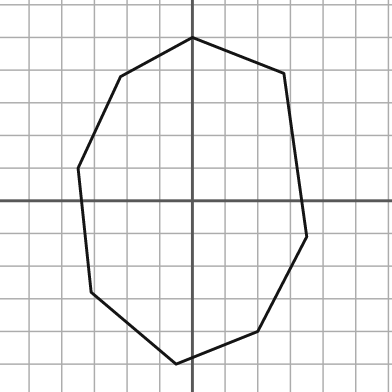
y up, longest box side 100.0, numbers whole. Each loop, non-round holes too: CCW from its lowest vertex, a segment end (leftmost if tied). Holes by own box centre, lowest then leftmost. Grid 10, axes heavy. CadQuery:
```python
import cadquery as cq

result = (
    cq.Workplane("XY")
    .moveTo(-5.0, -50.0)
    .lineTo(20.0, -40.0)
    .lineTo(35.0, -11.0)
    .lineTo(28.0, 39.0)
    .lineTo(0.0, 50.0)
    .lineTo(-22.0, 38.0)
    .lineTo(-35.0, 10.0)
    .lineTo(-31.0, -28.0)
    .close()
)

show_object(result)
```